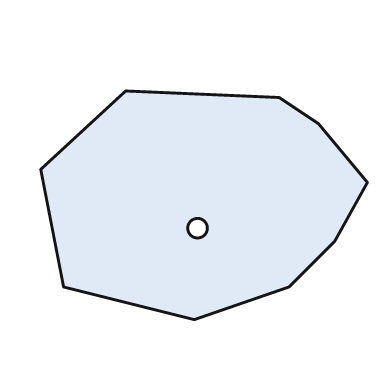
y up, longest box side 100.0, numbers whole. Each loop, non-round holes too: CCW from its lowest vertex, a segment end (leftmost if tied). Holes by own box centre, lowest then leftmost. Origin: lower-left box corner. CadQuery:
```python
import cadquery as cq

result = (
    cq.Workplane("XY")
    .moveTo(47.0, 0.0)
    .lineTo(76.0, 10.0)
    .lineTo(90.0, 24.0)
    .lineTo(100.0, 42.0)
    .lineTo(85.0, 60.0)
    .lineTo(73.0, 68.0)
    .lineTo(26.0, 70.0)
    .lineTo(0.0, 46.0)
    .lineTo(7.0, 10.0)
    .close()
    .moveTo(48.0, 28.0)
    .circle(3.0)
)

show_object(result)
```